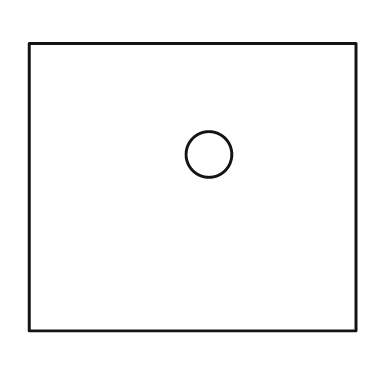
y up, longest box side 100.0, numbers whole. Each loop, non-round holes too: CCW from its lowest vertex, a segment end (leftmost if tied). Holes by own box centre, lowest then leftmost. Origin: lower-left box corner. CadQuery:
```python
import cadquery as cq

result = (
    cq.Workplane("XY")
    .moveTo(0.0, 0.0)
    .lineTo(100.0, 0.0)
    .lineTo(100.0, 88.0)
    .lineTo(0.0, 88.0)
    .close()
    .moveTo(55.0, 54.0)
    .circle(7.0)
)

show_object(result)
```